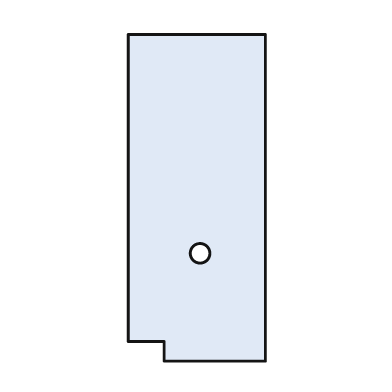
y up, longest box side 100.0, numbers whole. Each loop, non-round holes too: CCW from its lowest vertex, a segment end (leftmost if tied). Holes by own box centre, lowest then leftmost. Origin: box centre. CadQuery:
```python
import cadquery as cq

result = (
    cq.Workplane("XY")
    .moveTo(-10.0, -50.0)
    .lineTo(21.0, -50.0)
    .lineTo(21.0, 50.0)
    .lineTo(-21.0, 50.0)
    .lineTo(-21.0, -44.0)
    .lineTo(-10.0, -44.0)
    .close()
    .moveTo(1.0, -17.0)
    .circle(3.0)
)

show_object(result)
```